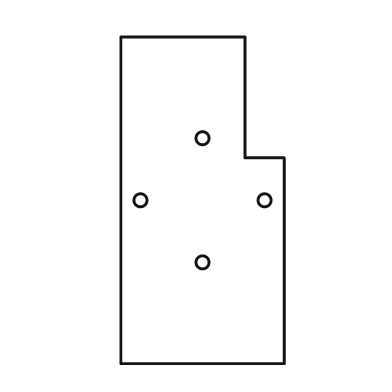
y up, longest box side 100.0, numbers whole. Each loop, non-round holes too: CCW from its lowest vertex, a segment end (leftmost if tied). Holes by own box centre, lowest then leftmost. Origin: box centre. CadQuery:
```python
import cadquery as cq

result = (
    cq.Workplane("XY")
    .moveTo(-25.0, -50.0)
    .lineTo(25.0, -50.0)
    .lineTo(25.0, 13.0)
    .lineTo(13.0, 13.0)
    .lineTo(13.0, 50.0)
    .lineTo(-25.0, 50.0)
    .close()
    .moveTo(0.0, -19.0)
    .circle(2.0)
    .moveTo(-19.0, 0.0)
    .circle(2.0)
    .moveTo(19.0, 0.0)
    .circle(2.0)
    .moveTo(0.0, 19.0)
    .circle(2.0)
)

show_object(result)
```